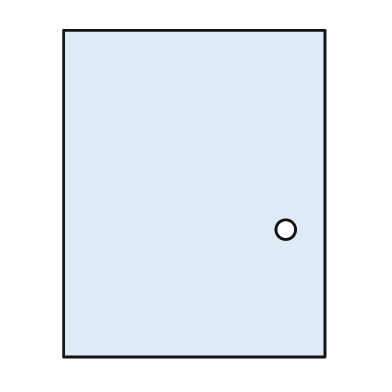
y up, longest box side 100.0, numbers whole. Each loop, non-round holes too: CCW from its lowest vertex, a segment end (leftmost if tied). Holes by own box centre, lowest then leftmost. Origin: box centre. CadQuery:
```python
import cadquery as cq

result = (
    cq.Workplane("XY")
    .moveTo(-40.0, -50.0)
    .lineTo(40.0, -50.0)
    .lineTo(40.0, 50.0)
    .lineTo(-40.0, 50.0)
    .close()
    .moveTo(28.0, -11.0)
    .circle(3.0)
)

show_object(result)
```